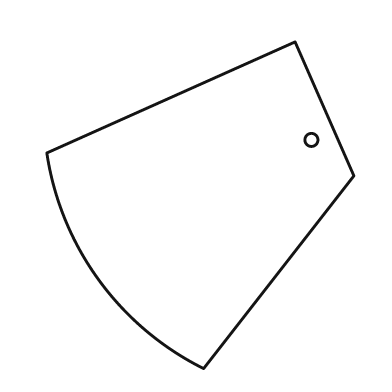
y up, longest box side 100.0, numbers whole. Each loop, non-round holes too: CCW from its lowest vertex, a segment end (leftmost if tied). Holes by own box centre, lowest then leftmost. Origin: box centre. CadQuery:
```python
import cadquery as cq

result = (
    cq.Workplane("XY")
    .moveTo(1.0, -50.0)
    .lineTo(47.0, 9.0)
    .lineTo(29.0, 50.0)
    .lineTo(-47.0, 16.0)
    .threePointArc((-31.0, -23.0), (1.0, -50.0))
    .close()
    .moveTo(34.0, 20.0)
    .circle(2.0)
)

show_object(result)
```